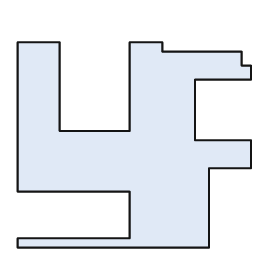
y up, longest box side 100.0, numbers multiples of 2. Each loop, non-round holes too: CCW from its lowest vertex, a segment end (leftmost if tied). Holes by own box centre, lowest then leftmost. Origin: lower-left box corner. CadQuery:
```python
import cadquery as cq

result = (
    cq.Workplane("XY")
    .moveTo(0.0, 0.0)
    .lineTo(82.0, 0.0)
    .lineTo(82.0, 34.0)
    .lineTo(100.0, 34.0)
    .lineTo(100.0, 46.0)
    .lineTo(76.0, 46.0)
    .lineTo(76.0, 72.0)
    .lineTo(100.0, 72.0)
    .lineTo(100.0, 78.0)
    .lineTo(96.0, 78.0)
    .lineTo(96.0, 84.0)
    .lineTo(62.0, 84.0)
    .lineTo(62.0, 88.0)
    .lineTo(48.0, 88.0)
    .lineTo(48.0, 50.0)
    .lineTo(18.0, 50.0)
    .lineTo(18.0, 88.0)
    .lineTo(0.0, 88.0)
    .lineTo(0.0, 24.0)
    .lineTo(48.0, 24.0)
    .lineTo(48.0, 4.0)
    .lineTo(0.0, 4.0)
    .close()
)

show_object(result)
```